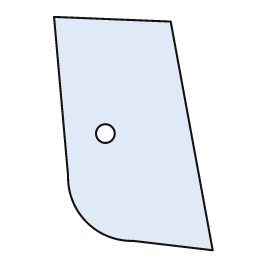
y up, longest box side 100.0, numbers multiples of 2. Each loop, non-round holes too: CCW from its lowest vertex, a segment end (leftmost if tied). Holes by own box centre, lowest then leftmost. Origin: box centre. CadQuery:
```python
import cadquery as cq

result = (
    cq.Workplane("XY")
    .moveTo(34.0, -50.0)
    .lineTo(16.0, 48.0)
    .lineTo(-34.0, 50.0)
    .lineTo(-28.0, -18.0)
    .threePointArc((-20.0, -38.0), (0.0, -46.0))
    .close()
    .moveTo(-12.0, 0.0)
    .circle(4.0)
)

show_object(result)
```